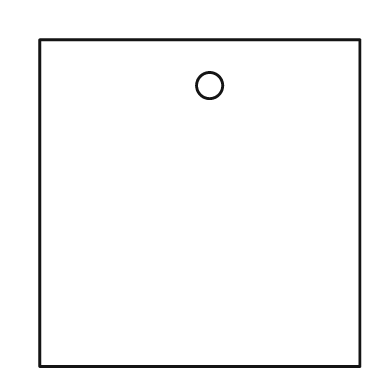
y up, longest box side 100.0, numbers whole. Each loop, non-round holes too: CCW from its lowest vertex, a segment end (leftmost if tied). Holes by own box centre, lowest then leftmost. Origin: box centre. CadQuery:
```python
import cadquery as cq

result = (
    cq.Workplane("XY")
    .moveTo(-49.0, -50.0)
    .lineTo(49.0, -50.0)
    .lineTo(49.0, 50.0)
    .lineTo(-49.0, 50.0)
    .close()
    .moveTo(3.0, 36.0)
    .circle(4.0)
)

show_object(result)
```